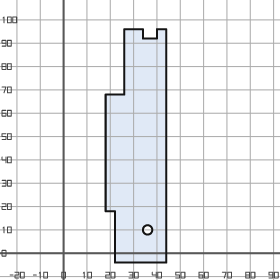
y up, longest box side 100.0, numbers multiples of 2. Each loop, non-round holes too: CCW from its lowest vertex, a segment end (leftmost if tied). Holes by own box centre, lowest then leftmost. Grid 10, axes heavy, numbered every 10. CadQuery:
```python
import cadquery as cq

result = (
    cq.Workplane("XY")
    .moveTo(22.0, -4.0)
    .lineTo(44.0, -4.0)
    .lineTo(44.0, 96.0)
    .lineTo(40.0, 96.0)
    .lineTo(40.0, 92.0)
    .lineTo(34.0, 92.0)
    .lineTo(34.0, 96.0)
    .lineTo(26.0, 96.0)
    .lineTo(26.0, 68.0)
    .lineTo(18.0, 68.0)
    .lineTo(18.0, 18.0)
    .lineTo(22.0, 18.0)
    .close()
    .moveTo(36.0, 10.0)
    .circle(2.0)
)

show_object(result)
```